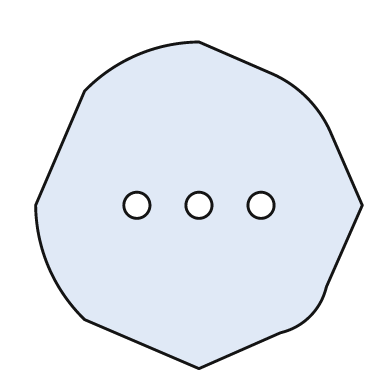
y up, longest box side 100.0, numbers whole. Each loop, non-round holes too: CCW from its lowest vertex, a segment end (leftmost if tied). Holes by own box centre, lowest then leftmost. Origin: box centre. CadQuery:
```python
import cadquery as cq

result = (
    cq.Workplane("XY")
    .moveTo(0.0, -50.0)
    .lineTo(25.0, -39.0)
    .threePointArc((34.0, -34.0), (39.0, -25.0))
    .lineTo(50.0, 0.0)
    .lineTo(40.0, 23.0)
    .threePointArc((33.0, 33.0), (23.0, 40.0))
    .lineTo(0.0, 50.0)
    .threePointArc((-19.0, 46.0), (-35.0, 35.0))
    .lineTo(-50.0, 0.0)
    .threePointArc((-46.0, -19.0), (-35.0, -35.0))
    .close()
    .moveTo(-19.0, 0.0)
    .circle(4.0)
    .moveTo(0.0, 0.0)
    .circle(4.0)
    .moveTo(19.0, 0.0)
    .circle(4.0)
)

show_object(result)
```